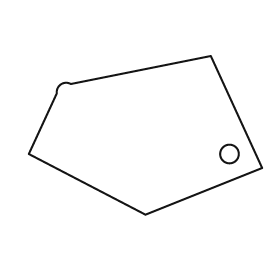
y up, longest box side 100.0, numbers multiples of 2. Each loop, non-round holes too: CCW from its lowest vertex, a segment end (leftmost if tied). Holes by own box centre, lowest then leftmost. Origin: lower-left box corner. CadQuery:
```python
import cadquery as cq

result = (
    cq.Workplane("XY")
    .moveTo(50.0, 0.0)
    .lineTo(100.0, 20.0)
    .lineTo(78.0, 68.0)
    .lineTo(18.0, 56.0)
    .threePointArc((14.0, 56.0), (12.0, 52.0))
    .lineTo(0.0, 26.0)
    .close()
    .moveTo(86.0, 26.0)
    .circle(4.0)
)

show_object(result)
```